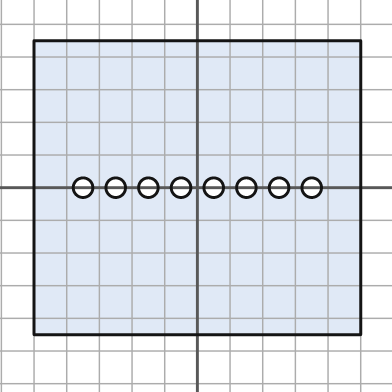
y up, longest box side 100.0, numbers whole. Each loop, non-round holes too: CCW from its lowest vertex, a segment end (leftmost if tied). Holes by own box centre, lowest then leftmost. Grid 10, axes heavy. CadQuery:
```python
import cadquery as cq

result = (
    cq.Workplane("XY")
    .moveTo(-50.0, -45.0)
    .lineTo(50.0, -45.0)
    .lineTo(50.0, 45.0)
    .lineTo(-50.0, 45.0)
    .close()
    .moveTo(-35.0, 0.0)
    .circle(3.0)
    .moveTo(-25.0, 0.0)
    .circle(3.0)
    .moveTo(-15.0, 0.0)
    .circle(3.0)
    .moveTo(-5.0, 0.0)
    .circle(3.0)
    .moveTo(5.0, 0.0)
    .circle(3.0)
    .moveTo(15.0, 0.0)
    .circle(3.0)
    .moveTo(25.0, 0.0)
    .circle(3.0)
    .moveTo(35.0, 0.0)
    .circle(3.0)
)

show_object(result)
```